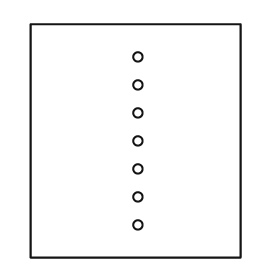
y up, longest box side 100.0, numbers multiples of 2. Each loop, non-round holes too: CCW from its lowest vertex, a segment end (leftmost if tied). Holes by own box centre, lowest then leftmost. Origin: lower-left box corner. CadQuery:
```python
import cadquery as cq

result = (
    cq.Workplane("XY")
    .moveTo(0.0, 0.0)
    .lineTo(90.0, 0.0)
    .lineTo(90.0, 100.0)
    .lineTo(0.0, 100.0)
    .close()
    .moveTo(46.0, 14.0)
    .circle(2.0)
    .moveTo(46.0, 26.0)
    .circle(2.0)
    .moveTo(46.0, 38.0)
    .circle(2.0)
    .moveTo(46.0, 50.0)
    .circle(2.0)
    .moveTo(46.0, 62.0)
    .circle(2.0)
    .moveTo(46.0, 74.0)
    .circle(2.0)
    .moveTo(46.0, 86.0)
    .circle(2.0)
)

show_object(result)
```